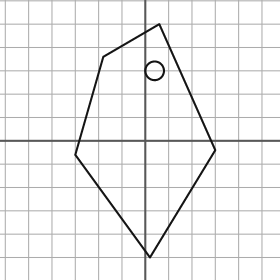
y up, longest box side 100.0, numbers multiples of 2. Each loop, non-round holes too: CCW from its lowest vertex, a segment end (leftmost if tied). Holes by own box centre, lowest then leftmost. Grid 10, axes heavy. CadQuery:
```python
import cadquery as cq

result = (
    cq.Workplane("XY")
    .moveTo(2.0, -50.0)
    .lineTo(30.0, -4.0)
    .lineTo(6.0, 50.0)
    .lineTo(-18.0, 36.0)
    .lineTo(-30.0, -6.0)
    .close()
    .moveTo(4.0, 30.0)
    .circle(4.0)
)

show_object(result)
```